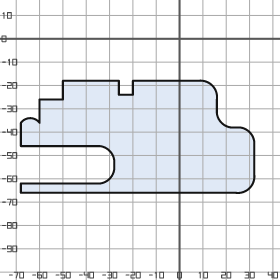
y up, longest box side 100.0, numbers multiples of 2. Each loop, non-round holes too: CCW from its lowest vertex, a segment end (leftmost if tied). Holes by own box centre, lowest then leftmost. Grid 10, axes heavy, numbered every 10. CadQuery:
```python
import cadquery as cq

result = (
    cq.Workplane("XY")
    .moveTo(-68.0, -66.0)
    .lineTo(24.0, -66.0)
    .threePointArc((30.0, -64.0), (32.0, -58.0))
    .lineTo(32.0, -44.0)
    .threePointArc((30.0, -40.0), (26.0, -38.0))
    .lineTo(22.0, -38.0)
    .threePointArc((18.0, -36.0), (16.0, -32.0))
    .lineTo(16.0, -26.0)
    .threePointArc((14.0, -20.0), (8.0, -18.0))
    .lineTo(-20.0, -18.0)
    .lineTo(-20.0, -24.0)
    .lineTo(-26.0, -24.0)
    .lineTo(-26.0, -18.0)
    .lineTo(-50.0, -18.0)
    .lineTo(-50.0, -26.0)
    .lineTo(-60.0, -26.0)
    .lineTo(-60.0, -36.0)
    .threePointArc((-64.0, -34.0), (-68.0, -36.0))
    .lineTo(-68.0, -46.0)
    .lineTo(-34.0, -46.0)
    .threePointArc((-30.0, -48.0), (-28.0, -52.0))
    .lineTo(-28.0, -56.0)
    .threePointArc((-30.0, -60.0), (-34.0, -62.0))
    .lineTo(-68.0, -62.0)
    .close()
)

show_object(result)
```